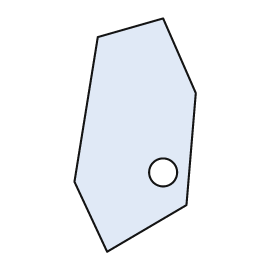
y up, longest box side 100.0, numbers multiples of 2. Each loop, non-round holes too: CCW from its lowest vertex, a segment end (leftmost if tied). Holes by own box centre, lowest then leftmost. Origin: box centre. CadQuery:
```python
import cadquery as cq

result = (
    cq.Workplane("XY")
    .moveTo(-12.0, -50.0)
    .lineTo(22.0, -30.0)
    .lineTo(26.0, 18.0)
    .lineTo(12.0, 50.0)
    .lineTo(-16.0, 42.0)
    .lineTo(-26.0, -20.0)
    .close()
    .moveTo(12.0, -16.0)
    .circle(6.0)
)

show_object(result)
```